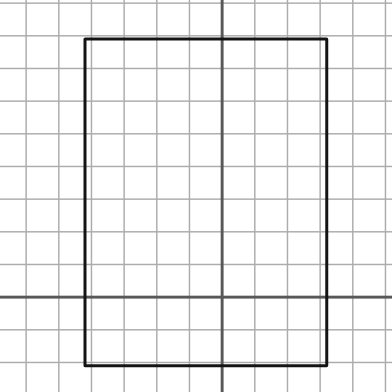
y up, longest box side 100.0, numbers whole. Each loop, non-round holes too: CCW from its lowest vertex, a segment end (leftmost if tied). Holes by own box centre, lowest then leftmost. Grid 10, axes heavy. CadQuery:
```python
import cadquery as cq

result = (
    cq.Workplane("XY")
    .moveTo(-42.0, -21.0)
    .lineTo(32.0, -21.0)
    .lineTo(32.0, 79.0)
    .lineTo(-42.0, 79.0)
    .close()
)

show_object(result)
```